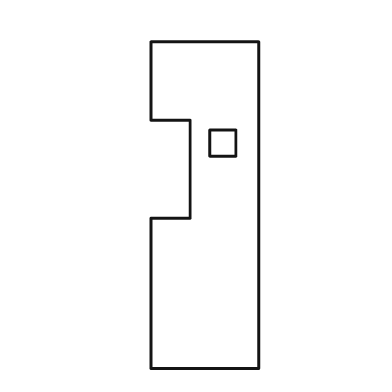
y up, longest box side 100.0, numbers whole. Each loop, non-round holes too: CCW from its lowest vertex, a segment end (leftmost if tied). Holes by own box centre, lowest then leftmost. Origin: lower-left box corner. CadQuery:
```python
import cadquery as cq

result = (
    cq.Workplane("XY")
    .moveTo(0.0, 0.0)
    .lineTo(33.0, 0.0)
    .lineTo(33.0, 100.0)
    .lineTo(0.0, 100.0)
    .lineTo(0.0, 76.0)
    .lineTo(12.0, 76.0)
    .lineTo(12.0, 46.0)
    .lineTo(0.0, 46.0)
    .close()
    .moveTo(18.0, 65.0)
    .lineTo(26.0, 65.0)
    .lineTo(26.0, 73.0)
    .lineTo(18.0, 73.0)
    .close()
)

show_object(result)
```